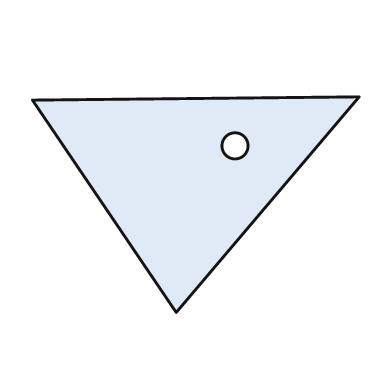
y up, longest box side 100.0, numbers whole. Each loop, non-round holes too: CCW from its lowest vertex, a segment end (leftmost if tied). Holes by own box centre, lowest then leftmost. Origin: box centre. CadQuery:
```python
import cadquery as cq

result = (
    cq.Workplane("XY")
    .moveTo(-6.0, -33.0)
    .lineTo(50.0, 33.0)
    .lineTo(-50.0, 32.0)
    .close()
    .moveTo(12.0, 18.0)
    .circle(4.0)
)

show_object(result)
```